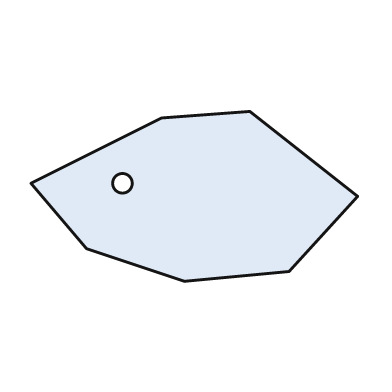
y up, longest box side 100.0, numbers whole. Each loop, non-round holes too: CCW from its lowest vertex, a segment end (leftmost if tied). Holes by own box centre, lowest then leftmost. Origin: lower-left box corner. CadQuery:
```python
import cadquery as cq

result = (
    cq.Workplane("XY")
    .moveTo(47.0, 0.0)
    .lineTo(79.0, 3.0)
    .lineTo(100.0, 26.0)
    .lineTo(67.0, 52.0)
    .lineTo(40.0, 50.0)
    .lineTo(0.0, 30.0)
    .lineTo(17.0, 10.0)
    .close()
    .moveTo(28.0, 30.0)
    .circle(3.0)
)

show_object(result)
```